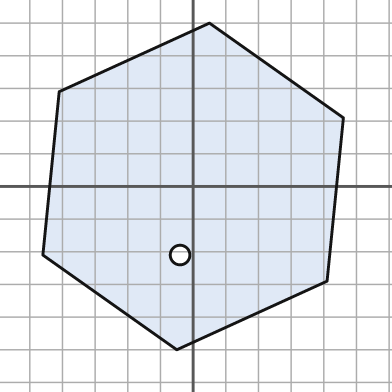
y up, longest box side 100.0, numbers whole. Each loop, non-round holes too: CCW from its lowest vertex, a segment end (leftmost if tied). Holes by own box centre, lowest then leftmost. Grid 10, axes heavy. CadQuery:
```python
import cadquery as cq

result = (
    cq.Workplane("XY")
    .moveTo(-5.0, -50.0)
    .lineTo(41.0, -29.0)
    .lineTo(46.0, 21.0)
    .lineTo(5.0, 50.0)
    .lineTo(-41.0, 29.0)
    .lineTo(-46.0, -21.0)
    .close()
    .moveTo(-4.0, -21.0)
    .circle(3.0)
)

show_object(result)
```